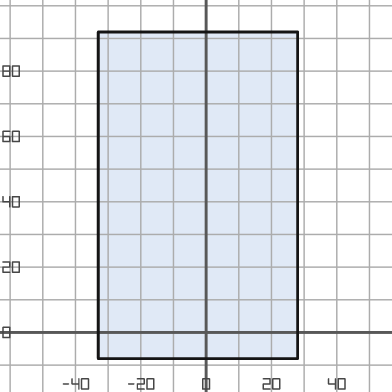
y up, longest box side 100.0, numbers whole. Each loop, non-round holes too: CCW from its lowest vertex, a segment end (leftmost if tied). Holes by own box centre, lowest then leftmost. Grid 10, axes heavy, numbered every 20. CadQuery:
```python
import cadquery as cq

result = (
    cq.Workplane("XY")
    .moveTo(-33.0, -8.0)
    .lineTo(28.0, -8.0)
    .lineTo(28.0, 92.0)
    .lineTo(-33.0, 92.0)
    .close()
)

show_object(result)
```